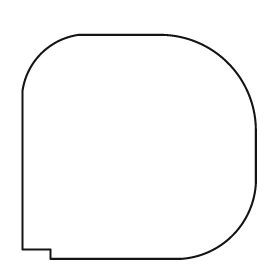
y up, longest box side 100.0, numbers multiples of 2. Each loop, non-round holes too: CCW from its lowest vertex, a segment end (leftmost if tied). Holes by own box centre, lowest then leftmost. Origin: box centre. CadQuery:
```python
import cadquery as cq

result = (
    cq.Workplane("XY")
    .moveTo(-38.0, -48.0)
    .lineTo(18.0, -48.0)
    .threePointArc((40.0, -38.0), (50.0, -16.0))
    .lineTo(50.0, 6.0)
    .threePointArc((38.0, 36.0), (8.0, 48.0))
    .lineTo(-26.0, 48.0)
    .threePointArc((-42.0, 40.0), (-50.0, 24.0))
    .lineTo(-50.0, -44.0)
    .lineTo(-38.0, -44.0)
    .close()
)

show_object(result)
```